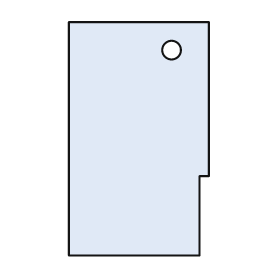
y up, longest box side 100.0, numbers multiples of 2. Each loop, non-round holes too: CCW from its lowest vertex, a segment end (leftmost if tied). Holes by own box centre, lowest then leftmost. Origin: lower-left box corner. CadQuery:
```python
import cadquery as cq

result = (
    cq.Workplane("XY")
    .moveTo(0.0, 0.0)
    .lineTo(56.0, 0.0)
    .lineTo(56.0, 34.0)
    .lineTo(60.0, 34.0)
    .lineTo(60.0, 100.0)
    .lineTo(0.0, 100.0)
    .close()
    .moveTo(44.0, 88.0)
    .circle(4.0)
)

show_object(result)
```